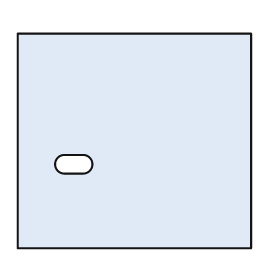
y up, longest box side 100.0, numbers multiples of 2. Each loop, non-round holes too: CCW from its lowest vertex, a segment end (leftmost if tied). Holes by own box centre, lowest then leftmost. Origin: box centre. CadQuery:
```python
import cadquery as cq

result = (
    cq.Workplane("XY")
    .moveTo(-50.0, -46.0)
    .lineTo(50.0, -46.0)
    .lineTo(50.0, 46.0)
    .lineTo(-50.0, 46.0)
    .close()
    .moveTo(-30.0, -14.0)
    .lineTo(-22.0, -14.0)
    .threePointArc((-18.0, -10.0), (-22.0, -6.0))
    .lineTo(-30.0, -6.0)
    .threePointArc((-34.0, -10.0), (-30.0, -14.0))
    .close()
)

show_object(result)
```